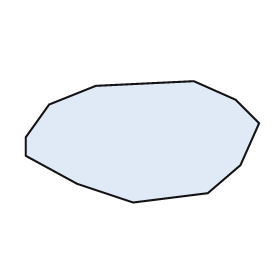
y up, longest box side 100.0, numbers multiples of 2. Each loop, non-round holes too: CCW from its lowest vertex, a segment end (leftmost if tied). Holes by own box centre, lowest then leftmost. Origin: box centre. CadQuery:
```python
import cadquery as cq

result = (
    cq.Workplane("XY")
    .moveTo(-4.0, -26.0)
    .lineTo(28.0, -22.0)
    .lineTo(42.0, -10.0)
    .lineTo(50.0, 8.0)
    .lineTo(40.0, 18.0)
    .lineTo(22.0, 26.0)
    .lineTo(-20.0, 24.0)
    .lineTo(-40.0, 16.0)
    .lineTo(-50.0, 2.0)
    .lineTo(-50.0, -6.0)
    .lineTo(-28.0, -18.0)
    .close()
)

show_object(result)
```